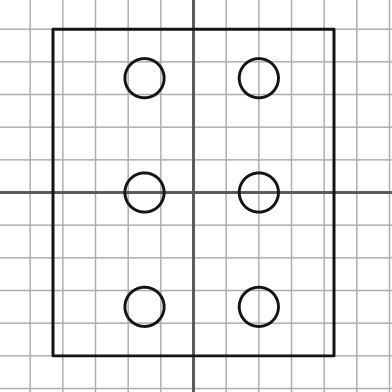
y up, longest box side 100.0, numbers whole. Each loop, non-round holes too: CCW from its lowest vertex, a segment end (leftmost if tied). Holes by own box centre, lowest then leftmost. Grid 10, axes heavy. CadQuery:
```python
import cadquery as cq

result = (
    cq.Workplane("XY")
    .moveTo(-43.0, -50.0)
    .lineTo(43.0, -50.0)
    .lineTo(43.0, 50.0)
    .lineTo(-43.0, 50.0)
    .close()
    .moveTo(-15.0, -35.0)
    .circle(6.0)
    .moveTo(20.0, -35.0)
    .circle(6.0)
    .moveTo(-15.0, 0.0)
    .circle(6.0)
    .moveTo(20.0, 0.0)
    .circle(6.0)
    .moveTo(-15.0, 35.0)
    .circle(6.0)
    .moveTo(20.0, 35.0)
    .circle(6.0)
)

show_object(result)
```